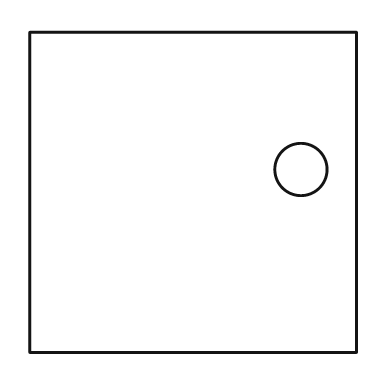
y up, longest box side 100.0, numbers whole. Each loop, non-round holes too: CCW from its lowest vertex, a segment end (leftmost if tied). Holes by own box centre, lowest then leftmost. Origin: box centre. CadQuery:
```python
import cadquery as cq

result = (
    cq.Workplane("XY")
    .moveTo(-50.0, -49.0)
    .lineTo(50.0, -49.0)
    .lineTo(50.0, 49.0)
    .lineTo(-50.0, 49.0)
    .close()
    .moveTo(33.0, 7.0)
    .circle(8.0)
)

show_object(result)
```